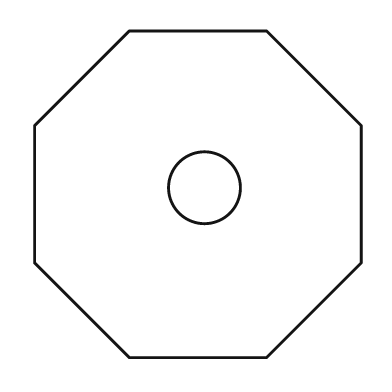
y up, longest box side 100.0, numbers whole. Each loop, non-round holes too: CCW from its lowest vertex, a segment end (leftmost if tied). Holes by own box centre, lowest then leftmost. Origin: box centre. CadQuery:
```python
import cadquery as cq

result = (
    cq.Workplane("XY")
    .moveTo(-21.0, -50.0)
    .lineTo(21.0, -50.0)
    .lineTo(50.0, -21.0)
    .lineTo(50.0, 21.0)
    .lineTo(21.0, 50.0)
    .lineTo(-21.0, 50.0)
    .lineTo(-50.0, 21.0)
    .lineTo(-50.0, -21.0)
    .close()
    .moveTo(2.0, 2.0)
    .circle(11.0)
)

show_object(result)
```